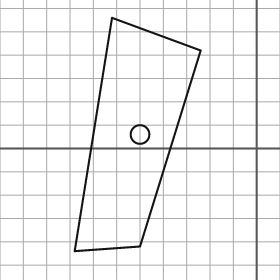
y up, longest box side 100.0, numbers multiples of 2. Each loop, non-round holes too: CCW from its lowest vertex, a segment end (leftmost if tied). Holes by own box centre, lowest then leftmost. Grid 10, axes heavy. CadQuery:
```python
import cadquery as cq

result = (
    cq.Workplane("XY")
    .moveTo(-78.0, -44.0)
    .lineTo(-50.0, -42.0)
    .lineTo(-24.0, 42.0)
    .lineTo(-62.0, 56.0)
    .close()
    .moveTo(-50.0, 6.0)
    .circle(4.0)
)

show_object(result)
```